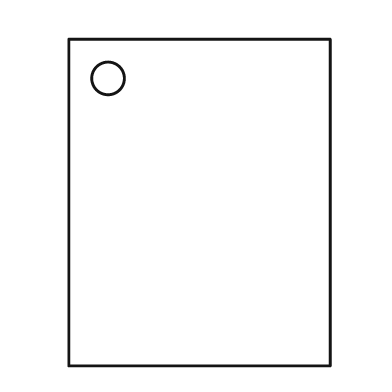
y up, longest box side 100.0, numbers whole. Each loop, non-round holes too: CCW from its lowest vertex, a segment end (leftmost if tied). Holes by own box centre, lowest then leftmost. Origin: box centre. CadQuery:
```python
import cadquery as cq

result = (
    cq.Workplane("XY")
    .moveTo(-40.0, -50.0)
    .lineTo(40.0, -50.0)
    .lineTo(40.0, 50.0)
    .lineTo(-40.0, 50.0)
    .close()
    .moveTo(-28.0, 38.0)
    .circle(5.0)
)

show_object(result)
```